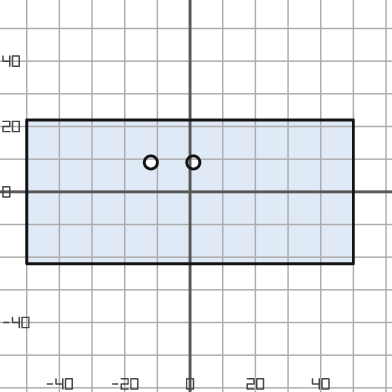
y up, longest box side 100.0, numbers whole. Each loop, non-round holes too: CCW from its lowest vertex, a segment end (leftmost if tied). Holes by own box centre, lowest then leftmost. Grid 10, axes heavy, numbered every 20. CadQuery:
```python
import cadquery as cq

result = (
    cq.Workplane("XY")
    .moveTo(-50.0, -22.0)
    .lineTo(50.0, -22.0)
    .lineTo(50.0, 22.0)
    .lineTo(-50.0, 22.0)
    .close()
    .moveTo(-12.0, 9.0)
    .circle(2.0)
    .moveTo(1.0, 9.0)
    .circle(2.0)
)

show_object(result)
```